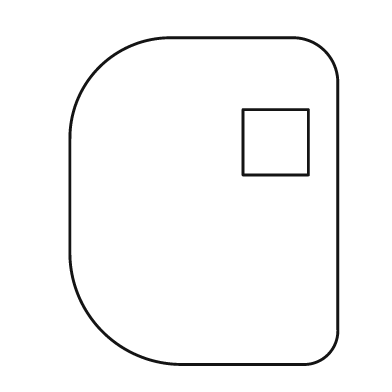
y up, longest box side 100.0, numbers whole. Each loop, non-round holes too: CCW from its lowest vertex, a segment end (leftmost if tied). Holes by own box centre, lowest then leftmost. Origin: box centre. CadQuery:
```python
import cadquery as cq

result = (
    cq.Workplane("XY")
    .moveTo(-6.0, -50.0)
    .lineTo(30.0, -50.0)
    .threePointArc((38.0, -47.0), (41.0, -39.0))
    .lineTo(41.0, 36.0)
    .threePointArc((37.0, 46.0), (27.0, 50.0))
    .lineTo(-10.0, 50.0)
    .threePointArc((-32.0, 41.0), (-41.0, 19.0))
    .lineTo(-41.0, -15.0)
    .threePointArc((-31.0, -40.0), (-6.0, -50.0))
    .close()
    .moveTo(12.0, 8.0)
    .lineTo(32.0, 8.0)
    .lineTo(32.0, 28.0)
    .lineTo(12.0, 28.0)
    .close()
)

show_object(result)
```